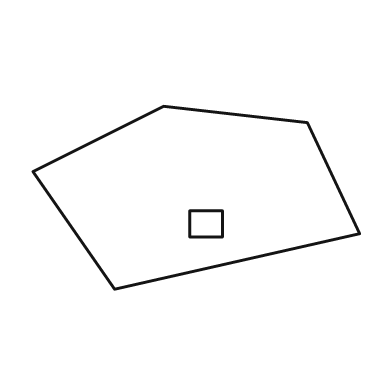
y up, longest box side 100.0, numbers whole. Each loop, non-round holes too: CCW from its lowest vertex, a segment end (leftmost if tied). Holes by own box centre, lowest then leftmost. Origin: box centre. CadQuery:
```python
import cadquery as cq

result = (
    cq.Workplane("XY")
    .moveTo(-25.0, -28.0)
    .lineTo(50.0, -11.0)
    .lineTo(34.0, 23.0)
    .lineTo(-10.0, 28.0)
    .lineTo(-50.0, 8.0)
    .close()
    .moveTo(-2.0, -12.0)
    .lineTo(8.0, -12.0)
    .lineTo(8.0, -4.0)
    .lineTo(-2.0, -4.0)
    .close()
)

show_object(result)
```